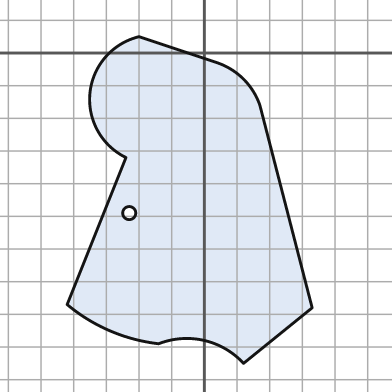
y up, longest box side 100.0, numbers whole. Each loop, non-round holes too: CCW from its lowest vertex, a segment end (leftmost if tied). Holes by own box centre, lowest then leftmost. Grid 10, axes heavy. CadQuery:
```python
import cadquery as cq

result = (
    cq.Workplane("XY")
    .moveTo(12.0, -95.0)
    .lineTo(33.0, -78.0)
    .lineTo(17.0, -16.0)
    .threePointArc((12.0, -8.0), (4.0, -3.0))
    .lineTo(-20.0, 5.0)
    .threePointArc((-35.0, -12.0), (-24.0, -32.0))
    .lineTo(-42.0, -77.0)
    .threePointArc((-29.0, -85.0), (-14.0, -89.0))
    .threePointArc((0.0, -88.0), (12.0, -95.0))
    .close()
    .moveTo(-23.0, -49.0)
    .circle(2.0)
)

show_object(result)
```